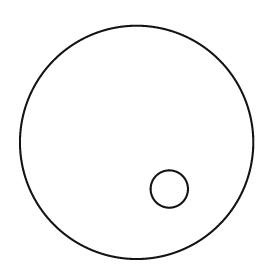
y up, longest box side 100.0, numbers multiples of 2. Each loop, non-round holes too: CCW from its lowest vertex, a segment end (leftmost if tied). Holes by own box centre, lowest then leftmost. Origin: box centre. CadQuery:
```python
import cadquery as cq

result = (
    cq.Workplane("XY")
    .moveTo(0.0, 0.0)
    .circle(50.0)
    .moveTo(14.0, -20.0)
    .circle(8.0)
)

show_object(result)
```